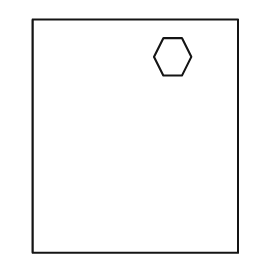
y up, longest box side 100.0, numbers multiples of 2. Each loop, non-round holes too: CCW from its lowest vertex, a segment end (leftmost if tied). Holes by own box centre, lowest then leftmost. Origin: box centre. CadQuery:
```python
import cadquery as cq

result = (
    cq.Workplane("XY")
    .moveTo(-44.0, -50.0)
    .lineTo(44.0, -50.0)
    .lineTo(44.0, 50.0)
    .lineTo(-44.0, 50.0)
    .close()
    .moveTo(12.0, 26.0)
    .lineTo(20.0, 26.0)
    .lineTo(24.0, 34.0)
    .lineTo(20.0, 42.0)
    .lineTo(12.0, 42.0)
    .lineTo(8.0, 34.0)
    .close()
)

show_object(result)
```